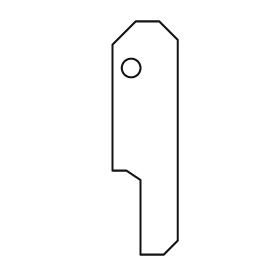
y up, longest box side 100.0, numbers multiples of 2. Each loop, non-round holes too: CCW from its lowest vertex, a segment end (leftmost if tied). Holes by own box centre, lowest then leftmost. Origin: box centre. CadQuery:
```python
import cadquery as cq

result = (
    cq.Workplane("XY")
    .moveTo(-2.0, -50.0)
    .lineTo(8.0, -50.0)
    .lineTo(14.0, -44.0)
    .lineTo(14.0, 42.0)
    .lineTo(6.0, 50.0)
    .lineTo(-4.0, 50.0)
    .lineTo(-14.0, 40.0)
    .lineTo(-14.0, -14.0)
    .lineTo(-8.0, -14.0)
    .lineTo(-2.0, -18.0)
    .close()
    .moveTo(-6.0, 30.0)
    .circle(4.0)
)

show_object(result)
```